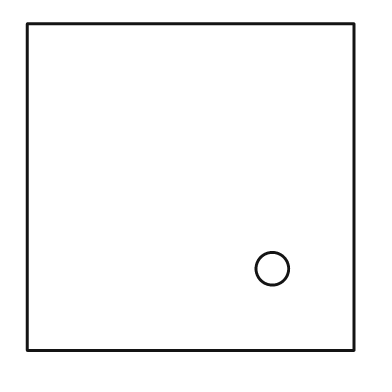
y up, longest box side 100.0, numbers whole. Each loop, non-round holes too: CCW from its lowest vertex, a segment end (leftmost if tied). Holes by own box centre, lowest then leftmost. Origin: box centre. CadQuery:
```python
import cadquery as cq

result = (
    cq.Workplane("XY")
    .moveTo(-50.0, -50.0)
    .lineTo(50.0, -50.0)
    .lineTo(50.0, 50.0)
    .lineTo(-50.0, 50.0)
    .close()
    .moveTo(25.0, -25.0)
    .circle(5.0)
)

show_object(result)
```